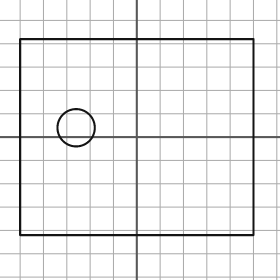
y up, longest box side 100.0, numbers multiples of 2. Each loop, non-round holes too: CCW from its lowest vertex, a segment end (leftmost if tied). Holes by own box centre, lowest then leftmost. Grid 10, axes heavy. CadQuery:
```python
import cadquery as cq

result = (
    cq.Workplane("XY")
    .moveTo(-50.0, -42.0)
    .lineTo(50.0, -42.0)
    .lineTo(50.0, 42.0)
    .lineTo(-50.0, 42.0)
    .close()
    .moveTo(-26.0, 4.0)
    .circle(8.0)
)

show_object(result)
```